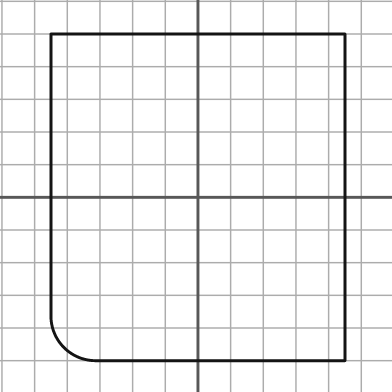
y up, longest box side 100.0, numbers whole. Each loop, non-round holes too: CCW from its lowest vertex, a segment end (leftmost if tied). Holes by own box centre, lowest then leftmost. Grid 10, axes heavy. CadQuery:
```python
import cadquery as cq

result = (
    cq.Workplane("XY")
    .moveTo(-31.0, -50.0)
    .lineTo(45.0, -50.0)
    .lineTo(45.0, 50.0)
    .lineTo(-45.0, 50.0)
    .lineTo(-45.0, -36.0)
    .threePointArc((-41.0, -46.0), (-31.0, -50.0))
    .close()
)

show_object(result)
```